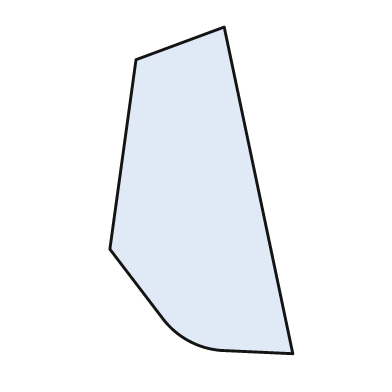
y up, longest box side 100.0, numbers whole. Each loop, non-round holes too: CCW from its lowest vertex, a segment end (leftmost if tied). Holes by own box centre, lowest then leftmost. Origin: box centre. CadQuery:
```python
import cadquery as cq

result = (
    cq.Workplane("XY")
    .moveTo(28.0, -50.0)
    .lineTo(7.0, 50.0)
    .lineTo(-20.0, 40.0)
    .lineTo(-28.0, -18.0)
    .lineTo(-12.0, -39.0)
    .threePointArc((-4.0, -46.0), (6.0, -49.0))
    .close()
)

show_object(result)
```